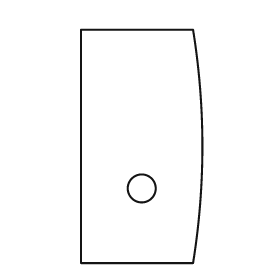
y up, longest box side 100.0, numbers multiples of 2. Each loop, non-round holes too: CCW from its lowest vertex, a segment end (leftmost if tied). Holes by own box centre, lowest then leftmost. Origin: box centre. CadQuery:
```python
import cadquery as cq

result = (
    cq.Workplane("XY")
    .moveTo(-26.0, -50.0)
    .lineTo(22.0, -50.0)
    .threePointArc((26.0, 0.0), (22.0, 50.0))
    .lineTo(-26.0, 50.0)
    .close()
    .moveTo(0.0, -18.0)
    .circle(6.0)
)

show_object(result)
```